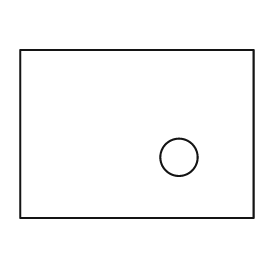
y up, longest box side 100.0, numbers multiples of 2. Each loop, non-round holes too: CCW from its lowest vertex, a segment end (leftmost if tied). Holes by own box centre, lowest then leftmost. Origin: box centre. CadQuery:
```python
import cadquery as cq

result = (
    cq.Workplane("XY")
    .moveTo(-50.0, -36.0)
    .lineTo(50.0, -36.0)
    .lineTo(50.0, 36.0)
    .lineTo(-50.0, 36.0)
    .close()
    .moveTo(18.0, -10.0)
    .circle(8.0)
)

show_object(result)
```